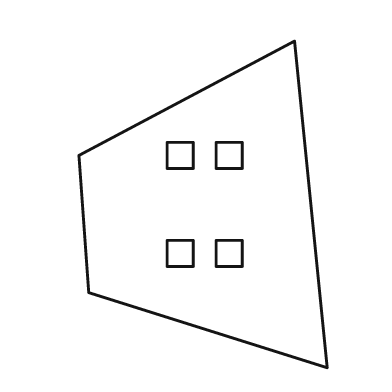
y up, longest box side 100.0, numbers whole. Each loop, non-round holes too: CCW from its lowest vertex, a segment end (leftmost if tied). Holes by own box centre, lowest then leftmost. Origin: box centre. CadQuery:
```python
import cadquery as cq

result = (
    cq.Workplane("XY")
    .moveTo(38.0, -50.0)
    .lineTo(28.0, 50.0)
    .lineTo(-38.0, 15.0)
    .lineTo(-35.0, -27.0)
    .close()
    .moveTo(-11.0, -19.0)
    .lineTo(-3.0, -19.0)
    .lineTo(-3.0, -11.0)
    .lineTo(-11.0, -11.0)
    .close()
    .moveTo(4.0, -19.0)
    .lineTo(12.0, -19.0)
    .lineTo(12.0, -11.0)
    .lineTo(4.0, -11.0)
    .close()
    .moveTo(-11.0, 11.0)
    .lineTo(-3.0, 11.0)
    .lineTo(-3.0, 19.0)
    .lineTo(-11.0, 19.0)
    .close()
    .moveTo(4.0, 11.0)
    .lineTo(12.0, 11.0)
    .lineTo(12.0, 19.0)
    .lineTo(4.0, 19.0)
    .close()
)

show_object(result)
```